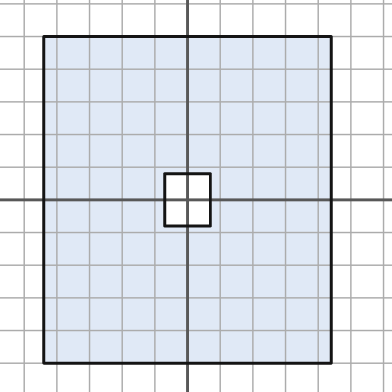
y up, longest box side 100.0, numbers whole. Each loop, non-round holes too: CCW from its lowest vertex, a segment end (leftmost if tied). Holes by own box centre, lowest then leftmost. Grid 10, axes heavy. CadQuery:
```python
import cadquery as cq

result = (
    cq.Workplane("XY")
    .moveTo(-44.0, -50.0)
    .lineTo(44.0, -50.0)
    .lineTo(44.0, 50.0)
    .lineTo(-44.0, 50.0)
    .close()
    .moveTo(-7.0, -8.0)
    .lineTo(7.0, -8.0)
    .lineTo(7.0, 8.0)
    .lineTo(-7.0, 8.0)
    .close()
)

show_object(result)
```